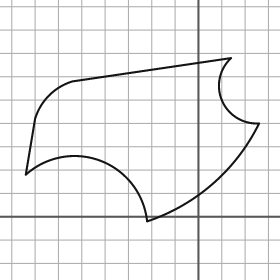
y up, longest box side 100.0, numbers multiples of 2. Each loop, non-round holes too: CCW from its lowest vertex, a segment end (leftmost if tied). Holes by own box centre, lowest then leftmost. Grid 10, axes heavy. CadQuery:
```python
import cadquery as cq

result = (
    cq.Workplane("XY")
    .moveTo(-22.0, -2.0)
    .threePointArc((6.0, 14.0), (26.0, 40.0))
    .threePointArc((10.0, 50.0), (14.0, 68.0))
    .lineTo(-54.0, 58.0)
    .threePointArc((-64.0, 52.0), (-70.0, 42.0))
    .lineTo(-74.0, 18.0)
    .threePointArc((-42.0, 24.0), (-22.0, -2.0))
    .close()
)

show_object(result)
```